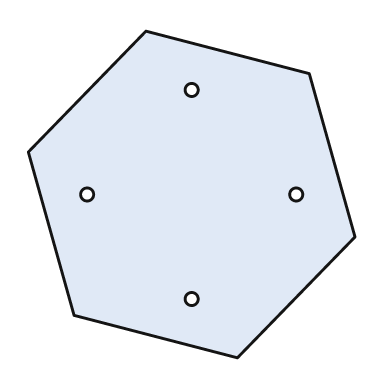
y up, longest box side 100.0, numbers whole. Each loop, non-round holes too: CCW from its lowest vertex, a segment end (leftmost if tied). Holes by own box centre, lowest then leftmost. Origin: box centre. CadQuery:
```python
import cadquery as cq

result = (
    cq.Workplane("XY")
    .moveTo(14.0, -50.0)
    .lineTo(50.0, -13.0)
    .lineTo(36.0, 37.0)
    .lineTo(-14.0, 50.0)
    .lineTo(-50.0, 13.0)
    .lineTo(-36.0, -37.0)
    .close()
    .moveTo(0.0, -32.0)
    .circle(2.0)
    .moveTo(-32.0, 0.0)
    .circle(2.0)
    .moveTo(32.0, 0.0)
    .circle(2.0)
    .moveTo(0.0, 32.0)
    .circle(2.0)
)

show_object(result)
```